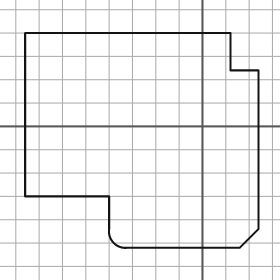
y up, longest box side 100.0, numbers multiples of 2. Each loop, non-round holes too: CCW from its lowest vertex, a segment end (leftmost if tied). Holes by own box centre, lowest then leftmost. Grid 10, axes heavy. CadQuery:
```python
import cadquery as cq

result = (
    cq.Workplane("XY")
    .moveTo(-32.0, -52.0)
    .lineTo(16.0, -52.0)
    .lineTo(24.0, -44.0)
    .lineTo(24.0, 24.0)
    .lineTo(12.0, 24.0)
    .lineTo(12.0, 40.0)
    .lineTo(-76.0, 40.0)
    .lineTo(-76.0, -30.0)
    .lineTo(-40.0, -30.0)
    .lineTo(-40.0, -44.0)
    .threePointArc((-38.0, -50.0), (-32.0, -52.0))
    .close()
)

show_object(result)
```